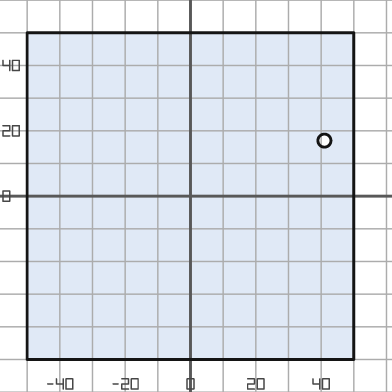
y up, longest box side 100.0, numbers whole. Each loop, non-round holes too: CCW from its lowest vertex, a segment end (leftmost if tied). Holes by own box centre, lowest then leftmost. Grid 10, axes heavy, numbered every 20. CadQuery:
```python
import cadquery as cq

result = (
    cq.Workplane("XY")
    .moveTo(-50.0, -50.0)
    .lineTo(50.0, -50.0)
    .lineTo(50.0, 50.0)
    .lineTo(-50.0, 50.0)
    .close()
    .moveTo(41.0, 17.0)
    .circle(2.0)
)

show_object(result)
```